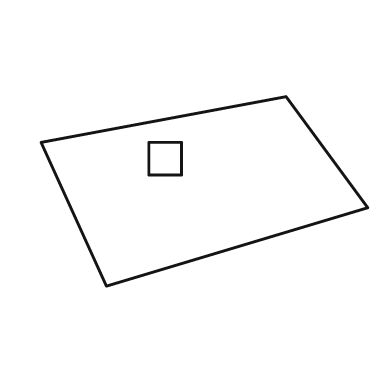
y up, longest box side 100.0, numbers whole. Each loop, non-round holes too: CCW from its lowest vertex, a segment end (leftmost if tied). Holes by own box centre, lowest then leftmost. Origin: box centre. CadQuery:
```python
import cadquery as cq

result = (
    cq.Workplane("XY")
    .moveTo(-30.0, -29.0)
    .lineTo(50.0, -5.0)
    .lineTo(25.0, 29.0)
    .lineTo(-50.0, 15.0)
    .close()
    .moveTo(-17.0, 5.0)
    .lineTo(-7.0, 5.0)
    .lineTo(-7.0, 15.0)
    .lineTo(-17.0, 15.0)
    .close()
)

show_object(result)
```